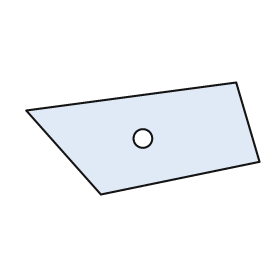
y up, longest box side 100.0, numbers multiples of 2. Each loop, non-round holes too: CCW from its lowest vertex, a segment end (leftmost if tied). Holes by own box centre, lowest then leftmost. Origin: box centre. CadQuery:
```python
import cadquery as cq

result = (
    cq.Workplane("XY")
    .moveTo(-18.0, -24.0)
    .lineTo(50.0, -10.0)
    .lineTo(40.0, 24.0)
    .lineTo(-50.0, 12.0)
    .close()
    .moveTo(0.0, 0.0)
    .circle(4.0)
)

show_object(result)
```